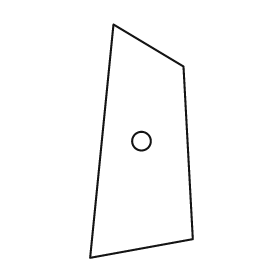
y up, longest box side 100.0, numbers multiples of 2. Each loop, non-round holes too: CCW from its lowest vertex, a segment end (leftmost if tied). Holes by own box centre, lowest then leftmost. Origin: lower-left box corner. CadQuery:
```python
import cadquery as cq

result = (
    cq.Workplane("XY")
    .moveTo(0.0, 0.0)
    .lineTo(44.0, 8.0)
    .lineTo(40.0, 82.0)
    .lineTo(10.0, 100.0)
    .close()
    .moveTo(22.0, 50.0)
    .circle(4.0)
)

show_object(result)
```